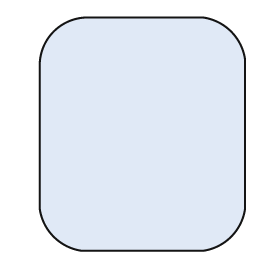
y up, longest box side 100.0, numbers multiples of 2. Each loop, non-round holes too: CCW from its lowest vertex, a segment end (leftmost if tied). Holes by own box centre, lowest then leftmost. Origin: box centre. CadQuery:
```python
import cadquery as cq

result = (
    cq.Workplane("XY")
    .moveTo(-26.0, -50.0)
    .lineTo(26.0, -50.0)
    .threePointArc((38.0, -44.0), (44.0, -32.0))
    .lineTo(44.0, 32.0)
    .threePointArc((38.0, 44.0), (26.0, 50.0))
    .lineTo(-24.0, 50.0)
    .threePointArc((-38.0, 44.0), (-44.0, 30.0))
    .lineTo(-44.0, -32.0)
    .threePointArc((-38.0, -44.0), (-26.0, -50.0))
    .close()
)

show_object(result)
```